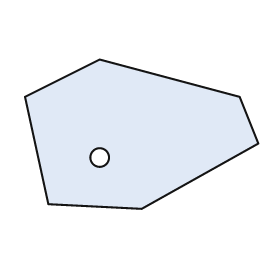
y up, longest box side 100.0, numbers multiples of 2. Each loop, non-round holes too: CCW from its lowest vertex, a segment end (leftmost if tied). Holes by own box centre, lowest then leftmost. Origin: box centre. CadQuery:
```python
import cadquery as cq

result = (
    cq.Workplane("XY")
    .moveTo(0.0, -32.0)
    .lineTo(50.0, -4.0)
    .lineTo(42.0, 16.0)
    .lineTo(-18.0, 32.0)
    .lineTo(-50.0, 16.0)
    .lineTo(-40.0, -30.0)
    .close()
    .moveTo(-18.0, -10.0)
    .circle(4.0)
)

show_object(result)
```